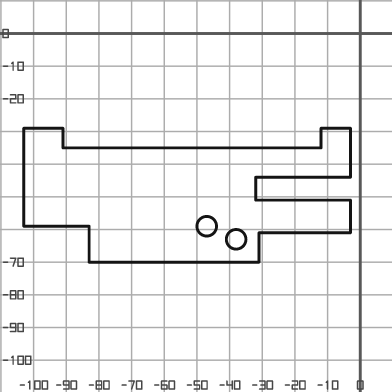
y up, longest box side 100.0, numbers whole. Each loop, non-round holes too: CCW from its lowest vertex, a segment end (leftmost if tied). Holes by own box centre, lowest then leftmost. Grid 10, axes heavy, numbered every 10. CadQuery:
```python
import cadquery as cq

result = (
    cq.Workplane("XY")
    .moveTo(-83.0, -70.0)
    .lineTo(-31.0, -70.0)
    .lineTo(-31.0, -61.0)
    .lineTo(-3.0, -61.0)
    .lineTo(-3.0, -51.0)
    .lineTo(-32.0, -51.0)
    .lineTo(-32.0, -44.0)
    .lineTo(-3.0, -44.0)
    .lineTo(-3.0, -29.0)
    .lineTo(-12.0, -29.0)
    .lineTo(-12.0, -35.0)
    .lineTo(-91.0, -35.0)
    .lineTo(-91.0, -29.0)
    .lineTo(-103.0, -29.0)
    .lineTo(-103.0, -59.0)
    .lineTo(-83.0, -59.0)
    .close()
    .moveTo(-38.0, -63.0)
    .circle(3.0)
    .moveTo(-47.0, -59.0)
    .circle(3.0)
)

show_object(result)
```